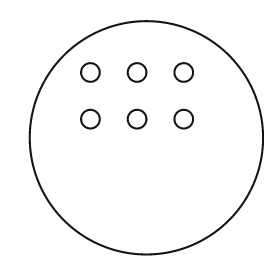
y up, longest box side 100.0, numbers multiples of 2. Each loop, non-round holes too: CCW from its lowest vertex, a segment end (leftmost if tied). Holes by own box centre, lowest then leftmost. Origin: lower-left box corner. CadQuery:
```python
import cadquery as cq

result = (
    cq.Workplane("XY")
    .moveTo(50.0, 50.0)
    .circle(50.0)
    .moveTo(26.0, 58.0)
    .circle(4.0)
    .moveTo(46.0, 58.0)
    .circle(4.0)
    .moveTo(66.0, 58.0)
    .circle(4.0)
    .moveTo(26.0, 78.0)
    .circle(4.0)
    .moveTo(46.0, 78.0)
    .circle(4.0)
    .moveTo(66.0, 78.0)
    .circle(4.0)
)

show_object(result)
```